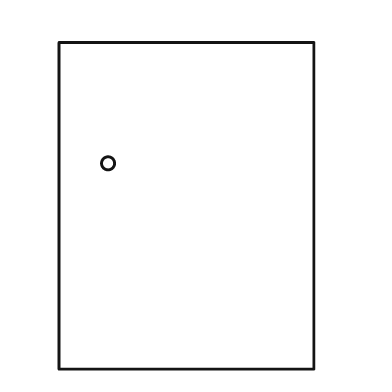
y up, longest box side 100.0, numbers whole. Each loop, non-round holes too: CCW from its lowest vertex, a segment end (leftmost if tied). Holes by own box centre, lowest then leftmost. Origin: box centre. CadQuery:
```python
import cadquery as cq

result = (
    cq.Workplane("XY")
    .moveTo(-39.0, -50.0)
    .lineTo(39.0, -50.0)
    .lineTo(39.0, 50.0)
    .lineTo(-39.0, 50.0)
    .close()
    .moveTo(-24.0, 13.0)
    .circle(2.0)
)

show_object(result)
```